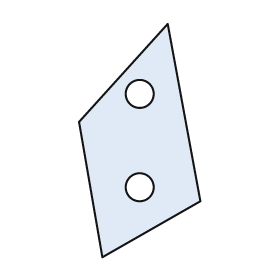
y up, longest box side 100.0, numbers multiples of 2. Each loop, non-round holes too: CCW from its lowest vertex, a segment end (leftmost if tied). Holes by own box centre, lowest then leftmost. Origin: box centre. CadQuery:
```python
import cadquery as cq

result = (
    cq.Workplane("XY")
    .moveTo(-16.0, -50.0)
    .lineTo(26.0, -26.0)
    .lineTo(12.0, 50.0)
    .lineTo(-26.0, 8.0)
    .close()
    .moveTo(0.0, -20.0)
    .circle(6.0)
    .moveTo(0.0, 20.0)
    .circle(6.0)
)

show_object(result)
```